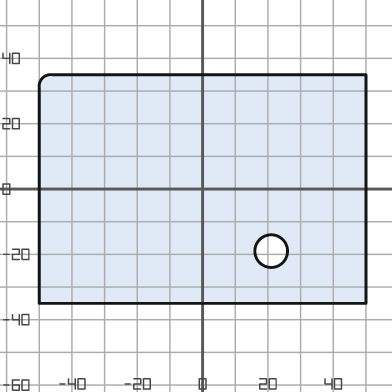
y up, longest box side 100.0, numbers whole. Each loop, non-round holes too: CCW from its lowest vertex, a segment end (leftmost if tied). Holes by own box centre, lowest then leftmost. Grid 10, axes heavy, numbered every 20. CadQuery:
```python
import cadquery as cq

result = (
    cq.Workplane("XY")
    .moveTo(-50.0, -35.0)
    .lineTo(50.0, -35.0)
    .lineTo(50.0, 35.0)
    .lineTo(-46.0, 35.0)
    .threePointArc((-49.0, 34.0), (-50.0, 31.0))
    .close()
    .moveTo(21.0, -19.0)
    .circle(5.0)
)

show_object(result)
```